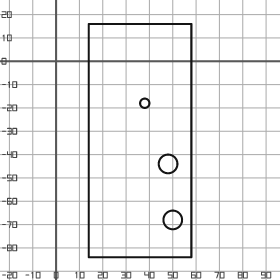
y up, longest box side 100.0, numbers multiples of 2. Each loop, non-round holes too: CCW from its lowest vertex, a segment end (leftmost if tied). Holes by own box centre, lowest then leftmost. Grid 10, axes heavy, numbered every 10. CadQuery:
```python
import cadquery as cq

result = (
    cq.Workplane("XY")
    .moveTo(14.0, -84.0)
    .lineTo(58.0, -84.0)
    .lineTo(58.0, 16.0)
    .lineTo(14.0, 16.0)
    .close()
    .moveTo(50.0, -68.0)
    .circle(4.0)
    .moveTo(48.0, -44.0)
    .circle(4.0)
    .moveTo(38.0, -18.0)
    .circle(2.0)
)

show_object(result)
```